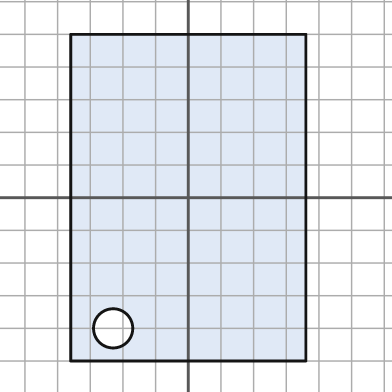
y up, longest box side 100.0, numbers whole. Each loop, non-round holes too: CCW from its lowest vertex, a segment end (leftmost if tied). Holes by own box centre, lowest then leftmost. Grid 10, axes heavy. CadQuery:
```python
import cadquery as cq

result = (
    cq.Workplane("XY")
    .moveTo(-36.0, -50.0)
    .lineTo(36.0, -50.0)
    .lineTo(36.0, 50.0)
    .lineTo(-36.0, 50.0)
    .close()
    .moveTo(-23.0, -40.0)
    .circle(6.0)
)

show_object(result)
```